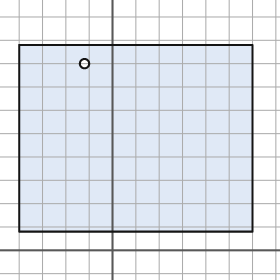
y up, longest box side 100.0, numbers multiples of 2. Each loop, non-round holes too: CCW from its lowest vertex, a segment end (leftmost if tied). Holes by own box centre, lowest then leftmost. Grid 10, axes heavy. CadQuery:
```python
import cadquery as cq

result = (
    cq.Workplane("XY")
    .moveTo(-40.0, 8.0)
    .lineTo(60.0, 8.0)
    .lineTo(60.0, 88.0)
    .lineTo(-40.0, 88.0)
    .close()
    .moveTo(-12.0, 80.0)
    .circle(2.0)
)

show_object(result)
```